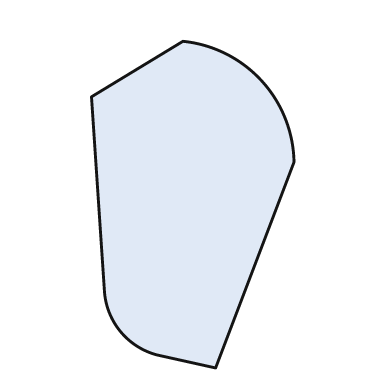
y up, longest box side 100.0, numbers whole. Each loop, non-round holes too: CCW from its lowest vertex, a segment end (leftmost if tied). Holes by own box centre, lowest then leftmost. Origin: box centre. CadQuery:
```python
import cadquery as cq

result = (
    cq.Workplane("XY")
    .moveTo(7.0, -50.0)
    .lineTo(31.0, 13.0)
    .threePointArc((21.0, 38.0), (-3.0, 50.0))
    .lineTo(-31.0, 33.0)
    .lineTo(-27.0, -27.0)
    .threePointArc((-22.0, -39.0), (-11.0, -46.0))
    .close()
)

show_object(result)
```